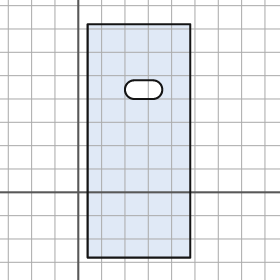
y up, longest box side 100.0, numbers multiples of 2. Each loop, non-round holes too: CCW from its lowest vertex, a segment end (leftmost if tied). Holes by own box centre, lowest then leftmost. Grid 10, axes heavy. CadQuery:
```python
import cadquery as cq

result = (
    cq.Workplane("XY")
    .moveTo(4.0, -28.0)
    .lineTo(48.0, -28.0)
    .lineTo(48.0, 72.0)
    .lineTo(4.0, 72.0)
    .close()
    .moveTo(24.0, 40.0)
    .lineTo(32.0, 40.0)
    .threePointArc((36.0, 44.0), (32.0, 48.0))
    .lineTo(24.0, 48.0)
    .threePointArc((20.0, 44.0), (24.0, 40.0))
    .close()
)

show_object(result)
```